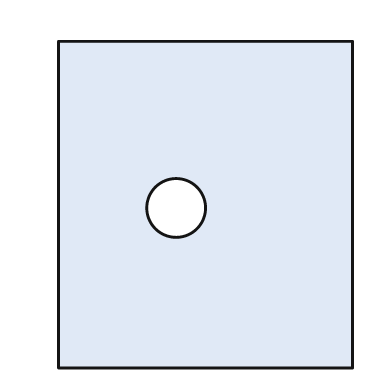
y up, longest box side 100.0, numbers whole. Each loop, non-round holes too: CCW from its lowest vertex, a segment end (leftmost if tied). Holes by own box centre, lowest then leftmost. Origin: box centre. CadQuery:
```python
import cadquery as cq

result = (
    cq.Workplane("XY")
    .moveTo(-45.0, -50.0)
    .lineTo(45.0, -50.0)
    .lineTo(45.0, 50.0)
    .lineTo(-45.0, 50.0)
    .close()
    .moveTo(-9.0, -1.0)
    .circle(9.0)
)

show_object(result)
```